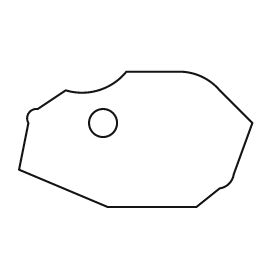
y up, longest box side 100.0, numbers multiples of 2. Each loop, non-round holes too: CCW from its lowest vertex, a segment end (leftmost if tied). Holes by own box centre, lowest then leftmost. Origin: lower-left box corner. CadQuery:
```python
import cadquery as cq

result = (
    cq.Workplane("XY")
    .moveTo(38.0, 0.0)
    .lineTo(76.0, 0.0)
    .lineTo(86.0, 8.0)
    .threePointArc((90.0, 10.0), (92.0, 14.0))
    .lineTo(100.0, 36.0)
    .lineTo(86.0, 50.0)
    .threePointArc((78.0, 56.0), (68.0, 58.0))
    .lineTo(46.0, 58.0)
    .threePointArc((34.0, 50.0), (20.0, 50.0))
    .lineTo(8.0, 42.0)
    .threePointArc((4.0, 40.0), (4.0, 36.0))
    .lineTo(0.0, 16.0)
    .close()
    .moveTo(36.0, 36.0)
    .circle(6.0)
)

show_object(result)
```